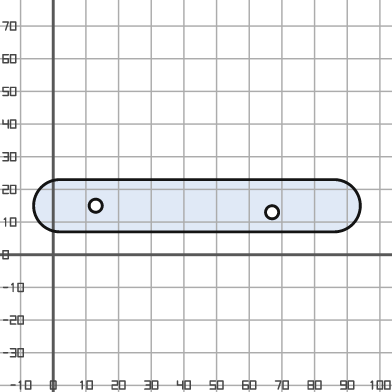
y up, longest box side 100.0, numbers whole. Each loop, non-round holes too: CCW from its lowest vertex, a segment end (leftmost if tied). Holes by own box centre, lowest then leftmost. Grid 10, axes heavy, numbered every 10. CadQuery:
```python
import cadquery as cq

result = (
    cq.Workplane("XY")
    .moveTo(2.0, 7.0)
    .lineTo(86.0, 7.0)
    .threePointArc((94.0, 15.0), (86.0, 23.0))
    .lineTo(2.0, 23.0)
    .threePointArc((-6.0, 15.0), (2.0, 7.0))
    .close()
    .moveTo(67.0, 13.0)
    .circle(2.0)
    .moveTo(13.0, 15.0)
    .circle(2.0)
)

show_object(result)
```